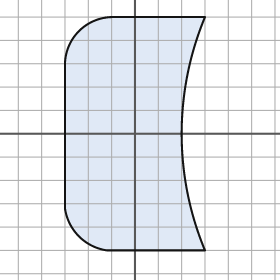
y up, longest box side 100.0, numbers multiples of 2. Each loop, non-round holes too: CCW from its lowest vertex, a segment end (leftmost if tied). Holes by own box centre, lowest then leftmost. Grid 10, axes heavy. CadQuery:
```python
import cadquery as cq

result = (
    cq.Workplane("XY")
    .moveTo(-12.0, -50.0)
    .lineTo(30.0, -50.0)
    .threePointArc((20.0, 0.0), (30.0, 50.0))
    .lineTo(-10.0, 50.0)
    .threePointArc((-24.0, 44.0), (-30.0, 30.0))
    .lineTo(-30.0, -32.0)
    .threePointArc((-24.0, -44.0), (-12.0, -50.0))
    .close()
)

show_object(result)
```